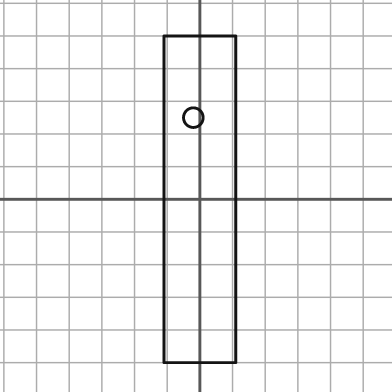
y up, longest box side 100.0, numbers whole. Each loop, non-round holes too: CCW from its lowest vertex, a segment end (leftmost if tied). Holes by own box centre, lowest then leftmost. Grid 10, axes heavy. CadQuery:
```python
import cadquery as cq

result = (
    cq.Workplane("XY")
    .moveTo(-11.0, -50.0)
    .lineTo(11.0, -50.0)
    .lineTo(11.0, 50.0)
    .lineTo(-11.0, 50.0)
    .close()
    .moveTo(-2.0, 25.0)
    .circle(3.0)
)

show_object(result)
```